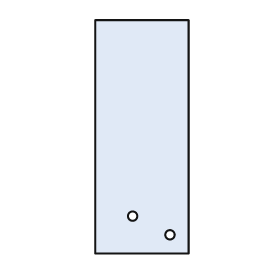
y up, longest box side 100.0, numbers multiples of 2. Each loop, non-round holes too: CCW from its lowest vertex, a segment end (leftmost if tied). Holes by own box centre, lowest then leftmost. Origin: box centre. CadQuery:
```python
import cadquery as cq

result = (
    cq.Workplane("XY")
    .moveTo(-20.0, -50.0)
    .lineTo(20.0, -50.0)
    .lineTo(20.0, 50.0)
    .lineTo(-20.0, 50.0)
    .close()
    .moveTo(12.0, -42.0)
    .circle(2.0)
    .moveTo(-4.0, -34.0)
    .circle(2.0)
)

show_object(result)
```